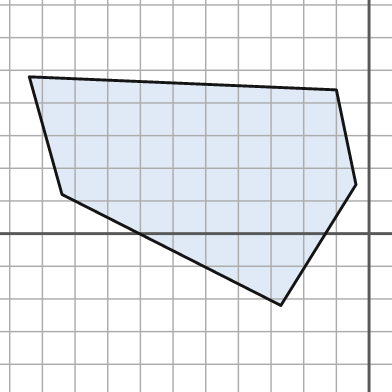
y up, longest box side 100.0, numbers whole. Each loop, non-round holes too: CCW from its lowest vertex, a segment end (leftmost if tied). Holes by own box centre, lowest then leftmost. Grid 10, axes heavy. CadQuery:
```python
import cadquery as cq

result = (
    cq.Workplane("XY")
    .moveTo(-27.0, -22.0)
    .lineTo(-4.0, 15.0)
    .lineTo(-10.0, 44.0)
    .lineTo(-104.0, 48.0)
    .lineTo(-94.0, 12.0)
    .close()
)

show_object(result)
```